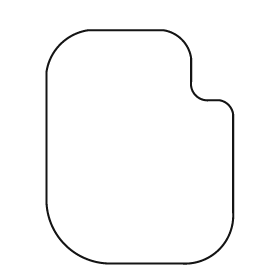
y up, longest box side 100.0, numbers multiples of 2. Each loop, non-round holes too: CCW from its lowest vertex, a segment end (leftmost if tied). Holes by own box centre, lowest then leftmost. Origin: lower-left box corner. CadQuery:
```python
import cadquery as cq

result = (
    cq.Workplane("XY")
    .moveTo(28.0, 0.0)
    .lineTo(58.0, 0.0)
    .threePointArc((74.0, 6.0), (80.0, 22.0))
    .lineTo(80.0, 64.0)
    .threePointArc((78.0, 68.0), (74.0, 70.0))
    .lineTo(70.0, 70.0)
    .threePointArc((64.0, 72.0), (62.0, 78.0))
    .lineTo(62.0, 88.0)
    .threePointArc((58.0, 96.0), (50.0, 100.0))
    .lineTo(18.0, 100.0)
    .threePointArc((6.0, 94.0), (0.0, 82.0))
    .lineTo(0.0, 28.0)
    .threePointArc((8.0, 8.0), (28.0, 0.0))
    .close()
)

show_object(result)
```